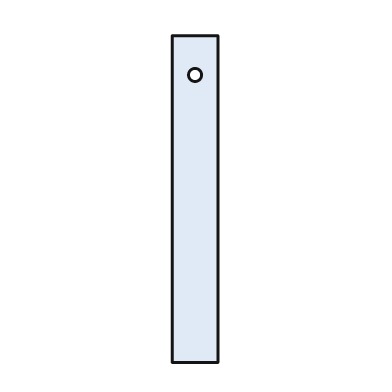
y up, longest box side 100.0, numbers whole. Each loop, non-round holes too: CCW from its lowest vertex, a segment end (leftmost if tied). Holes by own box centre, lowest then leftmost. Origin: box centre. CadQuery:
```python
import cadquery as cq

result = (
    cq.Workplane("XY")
    .moveTo(-7.0, -50.0)
    .lineTo(7.0, -50.0)
    .lineTo(7.0, 50.0)
    .lineTo(-7.0, 50.0)
    .close()
    .moveTo(0.0, 38.0)
    .circle(2.0)
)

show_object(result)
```